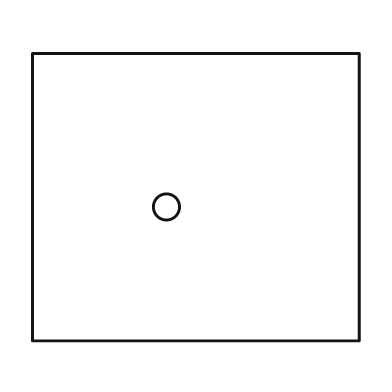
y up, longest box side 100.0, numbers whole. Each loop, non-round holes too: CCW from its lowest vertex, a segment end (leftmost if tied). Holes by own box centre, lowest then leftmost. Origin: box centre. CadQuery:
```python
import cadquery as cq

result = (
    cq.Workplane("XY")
    .moveTo(-50.0, -44.0)
    .lineTo(50.0, -44.0)
    .lineTo(50.0, 44.0)
    .lineTo(-50.0, 44.0)
    .close()
    .moveTo(-9.0, -3.0)
    .circle(4.0)
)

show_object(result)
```